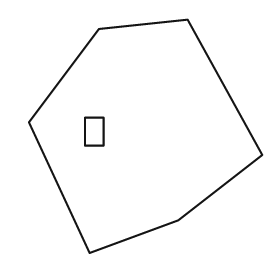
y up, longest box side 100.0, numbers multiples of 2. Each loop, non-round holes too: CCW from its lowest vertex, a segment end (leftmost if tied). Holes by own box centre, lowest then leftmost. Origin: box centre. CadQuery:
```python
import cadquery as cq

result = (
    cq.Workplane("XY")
    .moveTo(-24.0, -50.0)
    .lineTo(14.0, -36.0)
    .lineTo(50.0, -8.0)
    .lineTo(18.0, 50.0)
    .lineTo(-20.0, 46.0)
    .lineTo(-50.0, 6.0)
    .close()
    .moveTo(-26.0, -4.0)
    .lineTo(-18.0, -4.0)
    .lineTo(-18.0, 8.0)
    .lineTo(-26.0, 8.0)
    .close()
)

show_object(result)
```